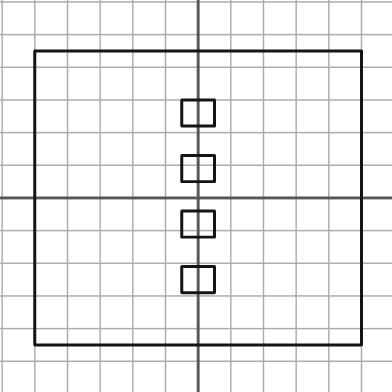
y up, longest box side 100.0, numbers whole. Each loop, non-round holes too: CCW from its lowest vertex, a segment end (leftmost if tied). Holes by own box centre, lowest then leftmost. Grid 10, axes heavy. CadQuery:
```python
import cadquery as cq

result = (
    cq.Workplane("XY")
    .moveTo(-50.0, -45.0)
    .lineTo(50.0, -45.0)
    .lineTo(50.0, 45.0)
    .lineTo(-50.0, 45.0)
    .close()
    .moveTo(-5.0, -29.0)
    .lineTo(5.0, -29.0)
    .lineTo(5.0, -21.0)
    .lineTo(-5.0, -21.0)
    .close()
    .moveTo(-5.0, -12.0)
    .lineTo(5.0, -12.0)
    .lineTo(5.0, -4.0)
    .lineTo(-5.0, -4.0)
    .close()
    .moveTo(-5.0, 5.0)
    .lineTo(5.0, 5.0)
    .lineTo(5.0, 13.0)
    .lineTo(-5.0, 13.0)
    .close()
    .moveTo(-5.0, 22.0)
    .lineTo(5.0, 22.0)
    .lineTo(5.0, 30.0)
    .lineTo(-5.0, 30.0)
    .close()
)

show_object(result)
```